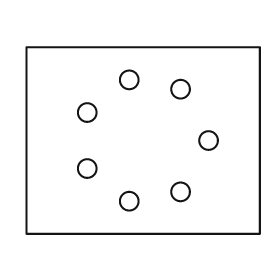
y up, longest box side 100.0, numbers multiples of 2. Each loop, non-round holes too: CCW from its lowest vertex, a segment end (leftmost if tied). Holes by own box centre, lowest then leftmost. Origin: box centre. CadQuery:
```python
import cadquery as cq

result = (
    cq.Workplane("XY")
    .moveTo(-50.0, -40.0)
    .lineTo(50.0, -40.0)
    .lineTo(50.0, 40.0)
    .lineTo(-50.0, 40.0)
    .close()
    .moveTo(-6.0, -26.0)
    .circle(4.0)
    .moveTo(16.0, -22.0)
    .circle(4.0)
    .moveTo(-24.0, -12.0)
    .circle(4.0)
    .moveTo(28.0, 0.0)
    .circle(4.0)
    .moveTo(-24.0, 12.0)
    .circle(4.0)
    .moveTo(16.0, 22.0)
    .circle(4.0)
    .moveTo(-6.0, 26.0)
    .circle(4.0)
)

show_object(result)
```